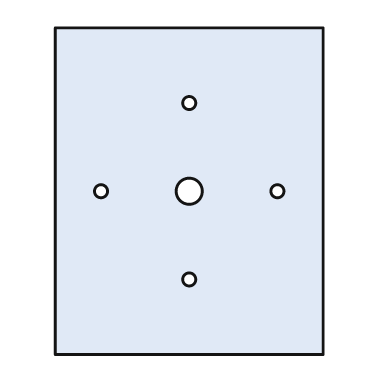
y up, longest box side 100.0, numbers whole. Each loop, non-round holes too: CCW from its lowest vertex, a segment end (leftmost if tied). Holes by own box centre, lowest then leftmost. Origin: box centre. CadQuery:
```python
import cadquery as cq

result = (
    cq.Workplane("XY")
    .moveTo(-41.0, -50.0)
    .lineTo(41.0, -50.0)
    .lineTo(41.0, 50.0)
    .lineTo(-41.0, 50.0)
    .close()
    .moveTo(0.0, -27.0)
    .circle(2.0)
    .moveTo(-27.0, 0.0)
    .circle(2.0)
    .moveTo(0.0, 0.0)
    .circle(4.0)
    .moveTo(27.0, 0.0)
    .circle(2.0)
    .moveTo(0.0, 27.0)
    .circle(2.0)
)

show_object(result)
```